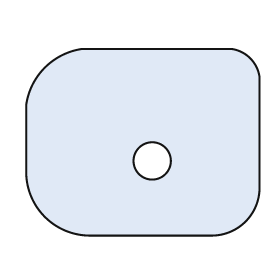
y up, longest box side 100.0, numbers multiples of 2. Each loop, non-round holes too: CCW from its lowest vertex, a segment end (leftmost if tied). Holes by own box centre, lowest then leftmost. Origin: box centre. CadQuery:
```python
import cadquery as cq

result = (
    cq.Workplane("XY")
    .moveTo(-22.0, -40.0)
    .lineTo(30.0, -40.0)
    .threePointArc((44.0, -34.0), (50.0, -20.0))
    .lineTo(50.0, 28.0)
    .threePointArc((46.0, 36.0), (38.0, 40.0))
    .lineTo(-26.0, 40.0)
    .threePointArc((-42.0, 32.0), (-50.0, 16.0))
    .lineTo(-50.0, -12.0)
    .threePointArc((-42.0, -32.0), (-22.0, -40.0))
    .close()
    .moveTo(4.0, -8.0)
    .circle(8.0)
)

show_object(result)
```